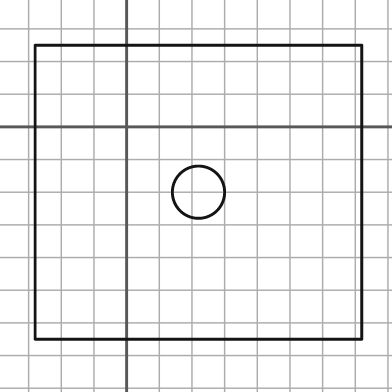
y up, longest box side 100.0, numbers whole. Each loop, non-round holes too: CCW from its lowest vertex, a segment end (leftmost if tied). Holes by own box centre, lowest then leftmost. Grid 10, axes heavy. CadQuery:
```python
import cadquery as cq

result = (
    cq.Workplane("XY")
    .moveTo(-28.0, -65.0)
    .lineTo(72.0, -65.0)
    .lineTo(72.0, 25.0)
    .lineTo(-28.0, 25.0)
    .close()
    .moveTo(22.0, -20.0)
    .circle(8.0)
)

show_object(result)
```